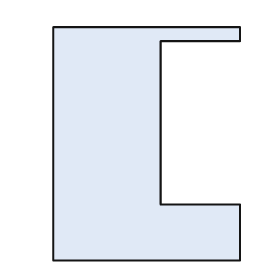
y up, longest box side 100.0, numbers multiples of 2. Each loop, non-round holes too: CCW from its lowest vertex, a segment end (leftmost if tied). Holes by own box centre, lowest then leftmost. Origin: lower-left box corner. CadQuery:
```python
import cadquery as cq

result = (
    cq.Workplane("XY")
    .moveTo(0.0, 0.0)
    .lineTo(80.0, 0.0)
    .lineTo(80.0, 24.0)
    .lineTo(46.0, 24.0)
    .lineTo(46.0, 94.0)
    .lineTo(80.0, 94.0)
    .lineTo(80.0, 100.0)
    .lineTo(0.0, 100.0)
    .close()
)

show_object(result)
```